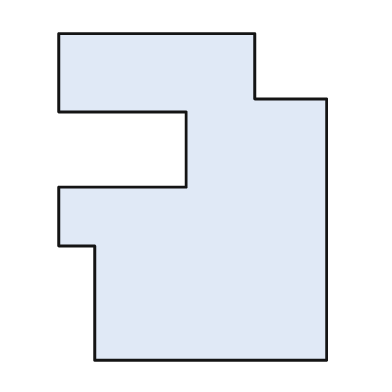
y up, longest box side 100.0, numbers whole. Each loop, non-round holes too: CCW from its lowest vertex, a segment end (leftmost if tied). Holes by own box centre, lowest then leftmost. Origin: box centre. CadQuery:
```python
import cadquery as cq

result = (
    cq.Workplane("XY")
    .moveTo(-30.0, -50.0)
    .lineTo(41.0, -50.0)
    .lineTo(41.0, 30.0)
    .lineTo(19.0, 30.0)
    .lineTo(19.0, 50.0)
    .lineTo(-41.0, 50.0)
    .lineTo(-41.0, 26.0)
    .lineTo(-2.0, 26.0)
    .lineTo(-2.0, 3.0)
    .lineTo(-41.0, 3.0)
    .lineTo(-41.0, -15.0)
    .lineTo(-30.0, -15.0)
    .close()
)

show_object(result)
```